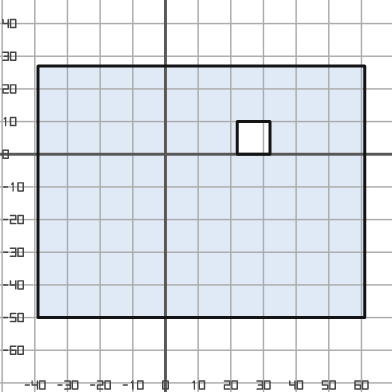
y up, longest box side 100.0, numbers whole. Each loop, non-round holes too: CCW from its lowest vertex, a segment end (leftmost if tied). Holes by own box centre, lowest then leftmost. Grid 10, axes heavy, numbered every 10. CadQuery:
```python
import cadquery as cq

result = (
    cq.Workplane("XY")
    .moveTo(-39.0, -50.0)
    .lineTo(61.0, -50.0)
    .lineTo(61.0, 27.0)
    .lineTo(-39.0, 27.0)
    .close()
    .moveTo(22.0, 0.0)
    .lineTo(32.0, 0.0)
    .lineTo(32.0, 10.0)
    .lineTo(22.0, 10.0)
    .close()
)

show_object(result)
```